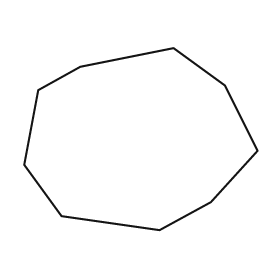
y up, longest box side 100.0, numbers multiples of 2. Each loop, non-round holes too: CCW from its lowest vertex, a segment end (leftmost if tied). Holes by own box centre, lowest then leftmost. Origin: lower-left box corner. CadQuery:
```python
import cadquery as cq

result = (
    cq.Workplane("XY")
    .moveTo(58.0, 0.0)
    .lineTo(80.0, 12.0)
    .lineTo(100.0, 34.0)
    .lineTo(86.0, 62.0)
    .lineTo(64.0, 78.0)
    .lineTo(24.0, 70.0)
    .lineTo(6.0, 60.0)
    .lineTo(0.0, 28.0)
    .lineTo(16.0, 6.0)
    .close()
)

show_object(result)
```